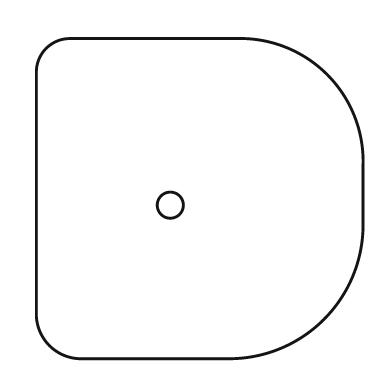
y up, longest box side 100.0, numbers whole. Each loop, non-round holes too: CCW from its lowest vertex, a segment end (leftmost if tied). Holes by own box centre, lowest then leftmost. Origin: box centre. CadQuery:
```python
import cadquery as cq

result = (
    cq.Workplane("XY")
    .moveTo(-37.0, -49.0)
    .lineTo(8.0, -49.0)
    .threePointArc((38.0, -37.0), (50.0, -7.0))
    .lineTo(50.0, 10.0)
    .threePointArc((39.0, 38.0), (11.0, 49.0))
    .lineTo(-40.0, 49.0)
    .threePointArc((-47.0, 46.0), (-50.0, 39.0))
    .lineTo(-50.0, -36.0)
    .threePointArc((-46.0, -45.0), (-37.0, -49.0))
    .close()
    .moveTo(-9.0, -2.0)
    .circle(4.0)
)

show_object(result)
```